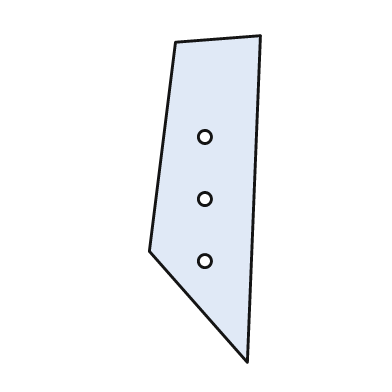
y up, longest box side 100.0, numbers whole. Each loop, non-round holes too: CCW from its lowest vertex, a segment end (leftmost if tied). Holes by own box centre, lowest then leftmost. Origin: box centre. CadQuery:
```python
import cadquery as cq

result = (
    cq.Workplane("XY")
    .moveTo(13.0, -50.0)
    .lineTo(17.0, 50.0)
    .lineTo(-9.0, 48.0)
    .lineTo(-17.0, -16.0)
    .close()
    .moveTo(0.0, -19.0)
    .circle(2.0)
    .moveTo(0.0, 0.0)
    .circle(2.0)
    .moveTo(0.0, 19.0)
    .circle(2.0)
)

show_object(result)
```